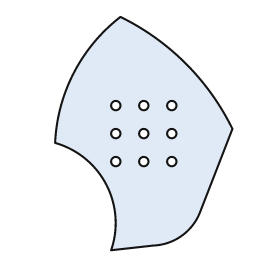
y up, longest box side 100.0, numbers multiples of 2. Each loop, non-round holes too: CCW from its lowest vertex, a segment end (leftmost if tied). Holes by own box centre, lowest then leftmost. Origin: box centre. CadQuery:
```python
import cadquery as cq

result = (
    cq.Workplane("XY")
    .moveTo(-14.0, -50.0)
    .lineTo(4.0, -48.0)
    .threePointArc((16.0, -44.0), (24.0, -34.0))
    .lineTo(38.0, 2.0)
    .threePointArc((18.0, 30.0), (-10.0, 50.0))
    .threePointArc((-30.0, 26.0), (-38.0, -4.0))
    .threePointArc((-16.0, -22.0), (-14.0, -50.0))
    .close()
    .moveTo(-12.0, -12.0)
    .circle(2.0)
    .moveTo(0.0, -12.0)
    .circle(2.0)
    .moveTo(12.0, -12.0)
    .circle(2.0)
    .moveTo(-12.0, 0.0)
    .circle(2.0)
    .moveTo(0.0, 0.0)
    .circle(2.0)
    .moveTo(12.0, 0.0)
    .circle(2.0)
    .moveTo(-12.0, 12.0)
    .circle(2.0)
    .moveTo(0.0, 12.0)
    .circle(2.0)
    .moveTo(12.0, 12.0)
    .circle(2.0)
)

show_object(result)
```